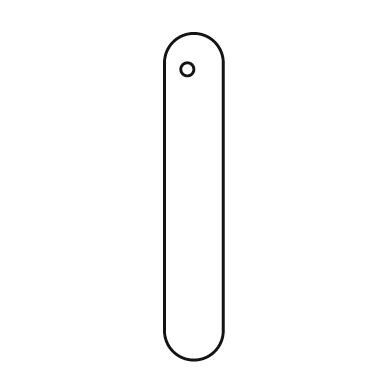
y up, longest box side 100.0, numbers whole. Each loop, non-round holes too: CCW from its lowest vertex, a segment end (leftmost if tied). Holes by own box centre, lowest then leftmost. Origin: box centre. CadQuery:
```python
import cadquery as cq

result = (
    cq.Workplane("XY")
    .moveTo(-9.0, -41.0)
    .threePointArc((0.0, -50.0), (9.0, -41.0))
    .lineTo(9.0, 41.0)
    .threePointArc((0.0, 50.0), (-9.0, 41.0))
    .close()
    .moveTo(-2.0, 39.0)
    .circle(2.0)
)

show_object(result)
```